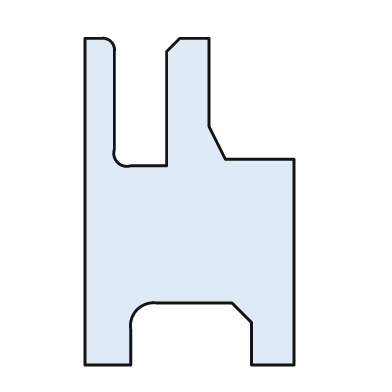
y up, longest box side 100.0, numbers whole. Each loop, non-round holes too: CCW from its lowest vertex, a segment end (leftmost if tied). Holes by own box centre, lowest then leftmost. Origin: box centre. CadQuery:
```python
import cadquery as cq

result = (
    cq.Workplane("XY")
    .moveTo(-32.0, -50.0)
    .lineTo(-18.0, -50.0)
    .lineTo(-18.0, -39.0)
    .threePointArc((-16.0, -33.0), (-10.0, -31.0))
    .lineTo(13.0, -31.0)
    .lineTo(19.0, -37.0)
    .lineTo(19.0, -50.0)
    .lineTo(32.0, -50.0)
    .lineTo(32.0, 13.0)
    .lineTo(11.0, 13.0)
    .lineTo(6.0, 23.0)
    .lineTo(6.0, 50.0)
    .lineTo(-3.0, 50.0)
    .lineTo(-7.0, 46.0)
    .lineTo(-7.0, 11.0)
    .lineTo(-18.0, 11.0)
    .threePointArc((-22.0, 12.0), (-23.0, 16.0))
    .lineTo(-23.0, 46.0)
    .threePointArc((-24.0, 49.0), (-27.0, 50.0))
    .lineTo(-32.0, 50.0)
    .close()
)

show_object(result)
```